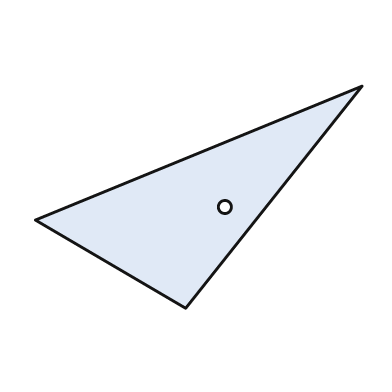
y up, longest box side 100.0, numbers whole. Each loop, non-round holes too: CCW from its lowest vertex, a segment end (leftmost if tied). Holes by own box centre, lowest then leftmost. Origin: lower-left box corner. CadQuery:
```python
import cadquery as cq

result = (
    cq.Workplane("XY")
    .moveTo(46.0, 0.0)
    .lineTo(100.0, 68.0)
    .lineTo(0.0, 27.0)
    .close()
    .moveTo(58.0, 31.0)
    .circle(2.0)
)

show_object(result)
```